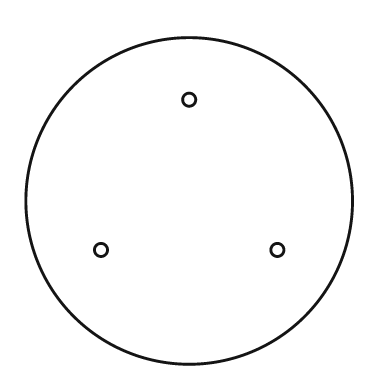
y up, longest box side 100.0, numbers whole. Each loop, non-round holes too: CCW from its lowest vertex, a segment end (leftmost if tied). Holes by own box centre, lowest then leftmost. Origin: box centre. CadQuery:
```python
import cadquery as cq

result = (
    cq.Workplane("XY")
    .moveTo(0.0, 0.0)
    .circle(50.0)
    .moveTo(-27.0, -15.0)
    .circle(2.0)
    .moveTo(27.0, -15.0)
    .circle(2.0)
    .moveTo(0.0, 31.0)
    .circle(2.0)
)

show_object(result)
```